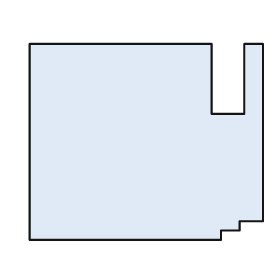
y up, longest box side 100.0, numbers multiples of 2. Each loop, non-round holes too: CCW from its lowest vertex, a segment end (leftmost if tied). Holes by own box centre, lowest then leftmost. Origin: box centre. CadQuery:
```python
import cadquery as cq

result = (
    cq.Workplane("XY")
    .moveTo(-50.0, -42.0)
    .lineTo(32.0, -42.0)
    .lineTo(32.0, -38.0)
    .lineTo(40.0, -38.0)
    .lineTo(40.0, -34.0)
    .lineTo(50.0, -34.0)
    .lineTo(50.0, 42.0)
    .lineTo(42.0, 42.0)
    .lineTo(42.0, 12.0)
    .lineTo(28.0, 12.0)
    .lineTo(28.0, 42.0)
    .lineTo(-50.0, 42.0)
    .close()
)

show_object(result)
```